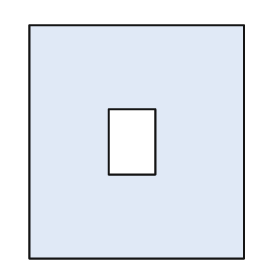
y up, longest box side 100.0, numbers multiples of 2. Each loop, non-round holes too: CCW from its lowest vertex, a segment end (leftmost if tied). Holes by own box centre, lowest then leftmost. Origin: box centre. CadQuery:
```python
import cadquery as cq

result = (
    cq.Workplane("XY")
    .moveTo(-46.0, -50.0)
    .lineTo(46.0, -50.0)
    .lineTo(46.0, 50.0)
    .lineTo(-46.0, 50.0)
    .close()
    .moveTo(-12.0, -14.0)
    .lineTo(8.0, -14.0)
    .lineTo(8.0, 14.0)
    .lineTo(-12.0, 14.0)
    .close()
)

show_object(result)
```